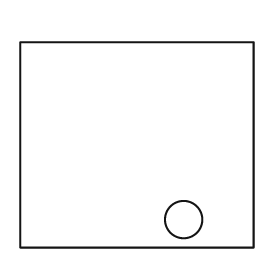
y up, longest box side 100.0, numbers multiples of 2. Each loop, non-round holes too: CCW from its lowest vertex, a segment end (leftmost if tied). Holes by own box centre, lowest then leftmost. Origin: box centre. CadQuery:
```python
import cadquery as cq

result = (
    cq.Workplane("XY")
    .moveTo(-50.0, -44.0)
    .lineTo(50.0, -44.0)
    .lineTo(50.0, 44.0)
    .lineTo(-50.0, 44.0)
    .close()
    .moveTo(20.0, -32.0)
    .circle(8.0)
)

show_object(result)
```